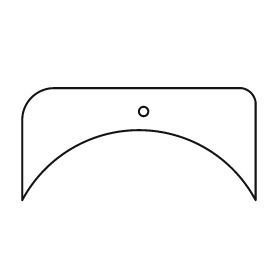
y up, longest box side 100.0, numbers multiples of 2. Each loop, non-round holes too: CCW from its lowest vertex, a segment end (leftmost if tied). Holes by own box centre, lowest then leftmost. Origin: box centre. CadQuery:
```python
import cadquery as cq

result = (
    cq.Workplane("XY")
    .moveTo(-50.0, -24.0)
    .threePointArc((0.0, 6.0), (50.0, -24.0))
    .lineTo(50.0, 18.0)
    .threePointArc((48.0, 22.0), (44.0, 24.0))
    .lineTo(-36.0, 24.0)
    .threePointArc((-46.0, 20.0), (-50.0, 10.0))
    .close()
    .moveTo(2.0, 14.0)
    .circle(2.0)
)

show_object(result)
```